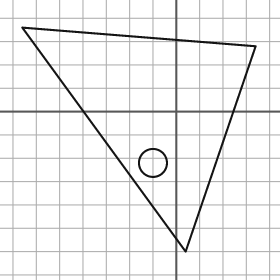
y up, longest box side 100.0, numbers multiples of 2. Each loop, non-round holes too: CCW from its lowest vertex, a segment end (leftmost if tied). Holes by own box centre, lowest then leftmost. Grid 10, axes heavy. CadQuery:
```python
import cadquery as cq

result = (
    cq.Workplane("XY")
    .moveTo(4.0, -60.0)
    .lineTo(34.0, 28.0)
    .lineTo(-66.0, 36.0)
    .close()
    .moveTo(-10.0, -22.0)
    .circle(6.0)
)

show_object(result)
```